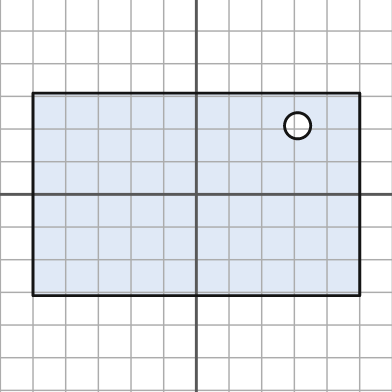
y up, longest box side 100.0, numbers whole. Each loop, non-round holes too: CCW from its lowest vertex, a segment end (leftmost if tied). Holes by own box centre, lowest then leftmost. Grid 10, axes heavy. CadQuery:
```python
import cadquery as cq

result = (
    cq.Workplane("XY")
    .moveTo(-50.0, -31.0)
    .lineTo(50.0, -31.0)
    .lineTo(50.0, 31.0)
    .lineTo(-50.0, 31.0)
    .close()
    .moveTo(31.0, 21.0)
    .circle(4.0)
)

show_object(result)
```